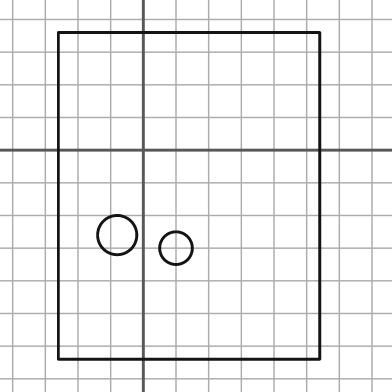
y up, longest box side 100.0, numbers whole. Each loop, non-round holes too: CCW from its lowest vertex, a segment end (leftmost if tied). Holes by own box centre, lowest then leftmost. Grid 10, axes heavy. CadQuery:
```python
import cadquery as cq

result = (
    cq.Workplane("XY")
    .moveTo(-26.0, -64.0)
    .lineTo(54.0, -64.0)
    .lineTo(54.0, 36.0)
    .lineTo(-26.0, 36.0)
    .close()
    .moveTo(10.0, -30.0)
    .circle(5.0)
    .moveTo(-8.0, -26.0)
    .circle(6.0)
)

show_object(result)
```